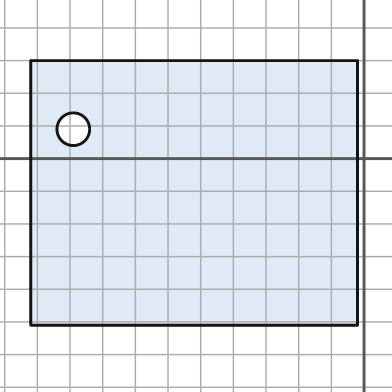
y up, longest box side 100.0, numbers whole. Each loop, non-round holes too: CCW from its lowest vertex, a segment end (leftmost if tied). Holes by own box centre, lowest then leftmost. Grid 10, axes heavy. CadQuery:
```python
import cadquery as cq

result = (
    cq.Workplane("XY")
    .moveTo(-102.0, -51.0)
    .lineTo(-2.0, -51.0)
    .lineTo(-2.0, 30.0)
    .lineTo(-102.0, 30.0)
    .close()
    .moveTo(-89.0, 9.0)
    .circle(5.0)
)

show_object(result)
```